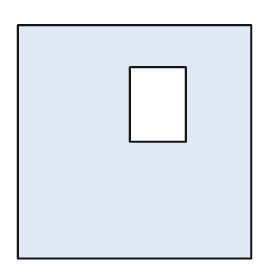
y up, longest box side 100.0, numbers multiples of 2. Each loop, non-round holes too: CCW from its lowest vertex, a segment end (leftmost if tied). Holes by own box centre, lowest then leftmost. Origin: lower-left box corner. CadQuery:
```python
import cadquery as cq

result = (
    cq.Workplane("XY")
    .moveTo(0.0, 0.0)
    .lineTo(100.0, 0.0)
    .lineTo(100.0, 100.0)
    .lineTo(0.0, 100.0)
    .close()
    .moveTo(48.0, 50.0)
    .lineTo(72.0, 50.0)
    .lineTo(72.0, 82.0)
    .lineTo(48.0, 82.0)
    .close()
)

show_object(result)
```